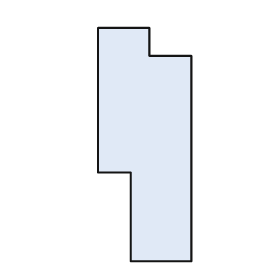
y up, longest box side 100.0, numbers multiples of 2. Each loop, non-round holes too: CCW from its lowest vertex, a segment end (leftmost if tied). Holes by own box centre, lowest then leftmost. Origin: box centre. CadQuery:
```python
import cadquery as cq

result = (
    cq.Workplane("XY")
    .moveTo(-6.0, -50.0)
    .lineTo(20.0, -50.0)
    .lineTo(20.0, 38.0)
    .lineTo(2.0, 38.0)
    .lineTo(2.0, 50.0)
    .lineTo(-20.0, 50.0)
    .lineTo(-20.0, -12.0)
    .lineTo(-6.0, -12.0)
    .close()
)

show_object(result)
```